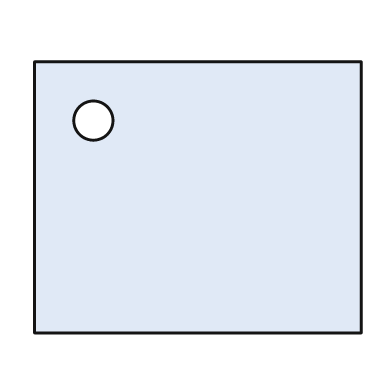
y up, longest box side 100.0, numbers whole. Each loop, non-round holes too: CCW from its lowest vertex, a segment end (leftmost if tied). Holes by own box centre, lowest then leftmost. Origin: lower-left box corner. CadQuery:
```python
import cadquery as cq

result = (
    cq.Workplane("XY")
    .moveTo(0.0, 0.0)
    .lineTo(100.0, 0.0)
    .lineTo(100.0, 83.0)
    .lineTo(0.0, 83.0)
    .close()
    .moveTo(18.0, 65.0)
    .circle(6.0)
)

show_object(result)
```